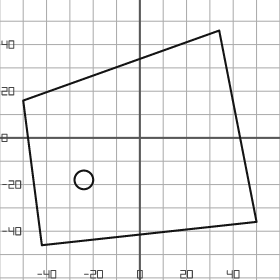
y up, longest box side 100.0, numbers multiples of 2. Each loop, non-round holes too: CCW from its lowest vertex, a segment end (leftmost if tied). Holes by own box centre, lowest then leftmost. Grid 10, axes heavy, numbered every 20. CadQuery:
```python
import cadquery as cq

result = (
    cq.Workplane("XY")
    .moveTo(-42.0, -46.0)
    .lineTo(50.0, -36.0)
    .lineTo(34.0, 46.0)
    .lineTo(-50.0, 16.0)
    .close()
    .moveTo(-24.0, -18.0)
    .circle(4.0)
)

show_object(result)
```